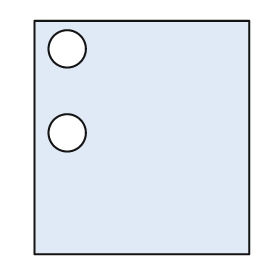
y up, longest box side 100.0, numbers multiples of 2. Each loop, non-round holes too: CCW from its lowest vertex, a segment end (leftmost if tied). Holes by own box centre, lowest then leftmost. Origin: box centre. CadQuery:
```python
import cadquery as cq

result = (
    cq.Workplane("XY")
    .moveTo(-46.0, -50.0)
    .lineTo(46.0, -50.0)
    .lineTo(46.0, 50.0)
    .lineTo(-46.0, 50.0)
    .close()
    .moveTo(-32.0, 2.0)
    .circle(8.0)
    .moveTo(-32.0, 38.0)
    .circle(8.0)
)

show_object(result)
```